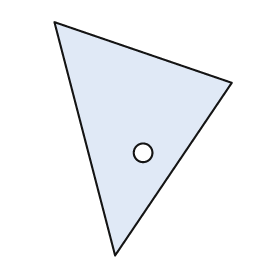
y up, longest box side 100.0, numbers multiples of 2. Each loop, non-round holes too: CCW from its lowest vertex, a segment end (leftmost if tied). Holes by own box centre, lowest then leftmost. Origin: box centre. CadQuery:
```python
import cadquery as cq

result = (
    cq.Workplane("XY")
    .moveTo(-12.0, -50.0)
    .lineTo(38.0, 24.0)
    .lineTo(-38.0, 50.0)
    .close()
    .moveTo(0.0, -6.0)
    .circle(4.0)
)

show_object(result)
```